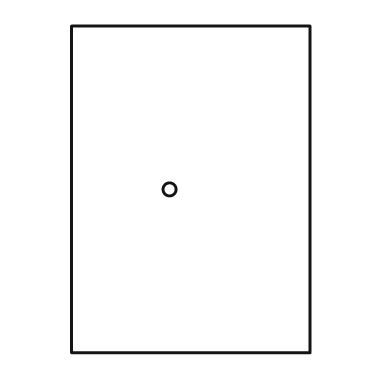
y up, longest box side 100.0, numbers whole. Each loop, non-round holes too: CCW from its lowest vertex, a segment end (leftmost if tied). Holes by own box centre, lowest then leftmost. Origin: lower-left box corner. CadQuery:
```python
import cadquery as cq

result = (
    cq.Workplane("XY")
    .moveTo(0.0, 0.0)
    .lineTo(73.0, 0.0)
    .lineTo(73.0, 100.0)
    .lineTo(0.0, 100.0)
    .close()
    .moveTo(30.0, 50.0)
    .circle(2.0)
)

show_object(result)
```